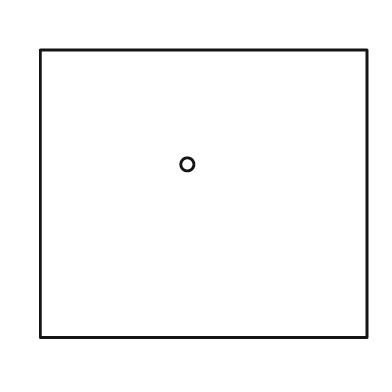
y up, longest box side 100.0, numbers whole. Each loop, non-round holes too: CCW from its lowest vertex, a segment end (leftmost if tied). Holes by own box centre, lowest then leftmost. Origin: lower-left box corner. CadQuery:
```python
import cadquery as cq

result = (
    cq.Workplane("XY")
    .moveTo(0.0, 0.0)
    .lineTo(100.0, 0.0)
    .lineTo(100.0, 88.0)
    .lineTo(0.0, 88.0)
    .close()
    .moveTo(45.0, 53.0)
    .circle(2.0)
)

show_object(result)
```